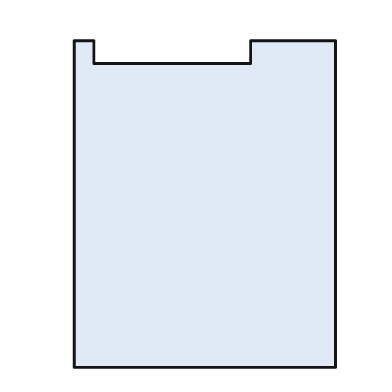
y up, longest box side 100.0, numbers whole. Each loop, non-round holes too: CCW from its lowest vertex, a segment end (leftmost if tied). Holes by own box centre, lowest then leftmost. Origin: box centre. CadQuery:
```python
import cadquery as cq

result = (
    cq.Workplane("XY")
    .moveTo(-40.0, -50.0)
    .lineTo(40.0, -50.0)
    .lineTo(40.0, 50.0)
    .lineTo(14.0, 50.0)
    .lineTo(14.0, 43.0)
    .lineTo(-34.0, 43.0)
    .lineTo(-34.0, 50.0)
    .lineTo(-40.0, 50.0)
    .close()
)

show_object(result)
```